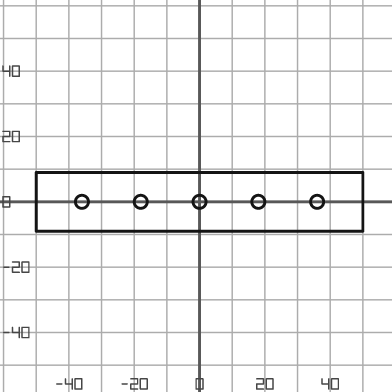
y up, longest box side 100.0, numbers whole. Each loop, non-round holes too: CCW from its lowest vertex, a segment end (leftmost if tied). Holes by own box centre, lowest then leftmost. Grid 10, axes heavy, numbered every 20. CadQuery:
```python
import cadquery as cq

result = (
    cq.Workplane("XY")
    .moveTo(-50.0, -9.0)
    .lineTo(50.0, -9.0)
    .lineTo(50.0, 9.0)
    .lineTo(-50.0, 9.0)
    .close()
    .moveTo(-36.0, 0.0)
    .circle(2.0)
    .moveTo(-18.0, 0.0)
    .circle(2.0)
    .moveTo(0.0, 0.0)
    .circle(2.0)
    .moveTo(18.0, 0.0)
    .circle(2.0)
    .moveTo(36.0, 0.0)
    .circle(2.0)
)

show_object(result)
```